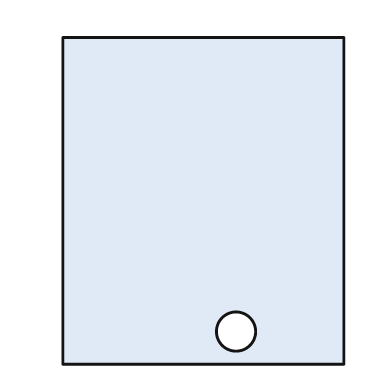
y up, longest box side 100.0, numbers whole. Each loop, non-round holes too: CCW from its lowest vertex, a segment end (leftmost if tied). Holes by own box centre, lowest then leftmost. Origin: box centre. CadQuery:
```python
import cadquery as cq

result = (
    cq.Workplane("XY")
    .moveTo(-43.0, -50.0)
    .lineTo(43.0, -50.0)
    .lineTo(43.0, 50.0)
    .lineTo(-43.0, 50.0)
    .close()
    .moveTo(10.0, -40.0)
    .circle(6.0)
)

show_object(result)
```